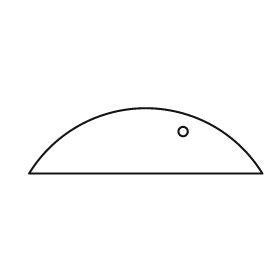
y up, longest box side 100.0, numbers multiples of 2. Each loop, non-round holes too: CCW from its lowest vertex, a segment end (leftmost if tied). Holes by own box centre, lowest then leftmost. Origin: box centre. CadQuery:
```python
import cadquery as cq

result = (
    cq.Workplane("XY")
    .moveTo(-50.0, -14.0)
    .lineTo(50.0, -14.0)
    .threePointArc((0.0, 14.0), (-50.0, -14.0))
    .close()
    .moveTo(16.0, 4.0)
    .circle(2.0)
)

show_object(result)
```